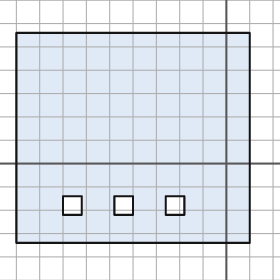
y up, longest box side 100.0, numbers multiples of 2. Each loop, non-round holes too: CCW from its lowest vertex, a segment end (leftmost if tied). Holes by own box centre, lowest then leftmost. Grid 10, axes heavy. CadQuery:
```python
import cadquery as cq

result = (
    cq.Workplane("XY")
    .moveTo(-90.0, -34.0)
    .lineTo(10.0, -34.0)
    .lineTo(10.0, 56.0)
    .lineTo(-90.0, 56.0)
    .close()
    .moveTo(-70.0, -22.0)
    .lineTo(-62.0, -22.0)
    .lineTo(-62.0, -14.0)
    .lineTo(-70.0, -14.0)
    .close()
    .moveTo(-48.0, -22.0)
    .lineTo(-40.0, -22.0)
    .lineTo(-40.0, -14.0)
    .lineTo(-48.0, -14.0)
    .close()
    .moveTo(-26.0, -22.0)
    .lineTo(-18.0, -22.0)
    .lineTo(-18.0, -14.0)
    .lineTo(-26.0, -14.0)
    .close()
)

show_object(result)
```